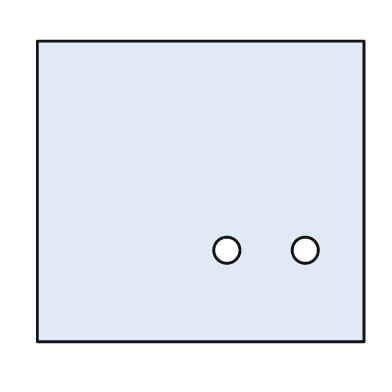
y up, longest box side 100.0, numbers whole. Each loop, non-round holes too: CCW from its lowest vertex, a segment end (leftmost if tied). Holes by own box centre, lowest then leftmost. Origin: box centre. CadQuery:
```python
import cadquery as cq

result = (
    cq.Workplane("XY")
    .moveTo(-50.0, -46.0)
    .lineTo(50.0, -46.0)
    .lineTo(50.0, 46.0)
    .lineTo(-50.0, 46.0)
    .close()
    .moveTo(8.0, -18.0)
    .circle(4.0)
    .moveTo(32.0, -18.0)
    .circle(4.0)
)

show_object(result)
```